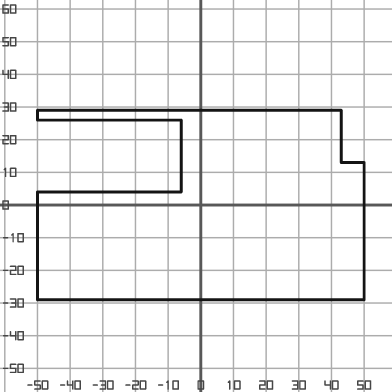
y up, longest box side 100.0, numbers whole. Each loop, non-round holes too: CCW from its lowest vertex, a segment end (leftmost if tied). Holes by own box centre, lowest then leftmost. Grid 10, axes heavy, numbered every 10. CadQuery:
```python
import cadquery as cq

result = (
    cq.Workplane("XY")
    .moveTo(-50.0, -29.0)
    .lineTo(50.0, -29.0)
    .lineTo(50.0, 13.0)
    .lineTo(43.0, 13.0)
    .lineTo(43.0, 29.0)
    .lineTo(-50.0, 29.0)
    .lineTo(-50.0, 26.0)
    .lineTo(-6.0, 26.0)
    .lineTo(-6.0, 4.0)
    .lineTo(-50.0, 4.0)
    .close()
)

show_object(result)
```